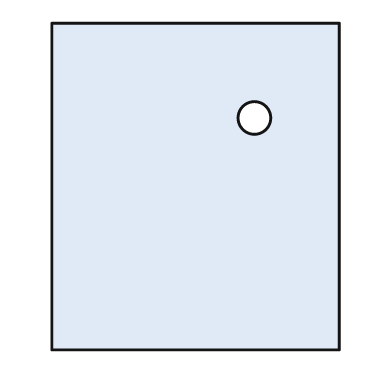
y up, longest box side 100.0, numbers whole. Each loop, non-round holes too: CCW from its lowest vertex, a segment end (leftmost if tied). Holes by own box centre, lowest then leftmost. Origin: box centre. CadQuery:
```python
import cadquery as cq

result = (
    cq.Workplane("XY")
    .moveTo(-44.0, -50.0)
    .lineTo(44.0, -50.0)
    .lineTo(44.0, 50.0)
    .lineTo(-44.0, 50.0)
    .close()
    .moveTo(18.0, 21.0)
    .circle(5.0)
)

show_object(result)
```